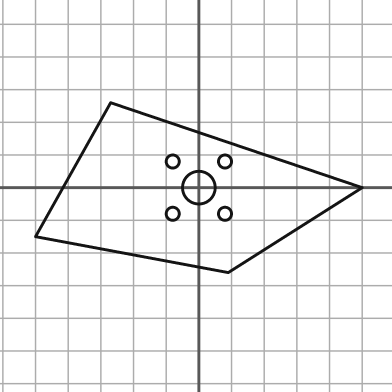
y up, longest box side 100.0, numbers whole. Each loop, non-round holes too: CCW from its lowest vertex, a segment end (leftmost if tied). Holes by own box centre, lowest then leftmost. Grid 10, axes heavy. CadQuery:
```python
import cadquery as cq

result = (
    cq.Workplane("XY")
    .moveTo(9.0, -26.0)
    .lineTo(50.0, 0.0)
    .lineTo(-27.0, 26.0)
    .lineTo(-50.0, -15.0)
    .close()
    .moveTo(-8.0, -8.0)
    .circle(2.0)
    .moveTo(8.0, -8.0)
    .circle(2.0)
    .moveTo(0.0, 0.0)
    .circle(5.0)
    .moveTo(-8.0, 8.0)
    .circle(2.0)
    .moveTo(8.0, 8.0)
    .circle(2.0)
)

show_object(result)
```